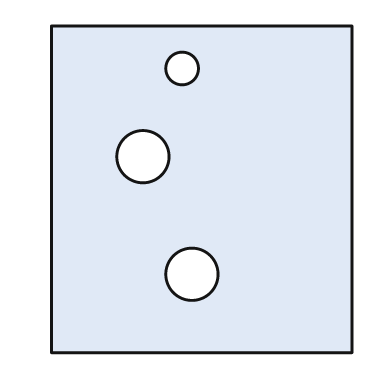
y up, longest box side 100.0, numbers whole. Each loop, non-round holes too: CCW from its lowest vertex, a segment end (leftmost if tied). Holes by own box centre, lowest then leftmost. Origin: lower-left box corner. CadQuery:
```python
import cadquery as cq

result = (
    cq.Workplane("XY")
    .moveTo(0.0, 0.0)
    .lineTo(92.0, 0.0)
    .lineTo(92.0, 100.0)
    .lineTo(0.0, 100.0)
    .close()
    .moveTo(43.0, 24.0)
    .circle(8.0)
    .moveTo(28.0, 60.0)
    .circle(8.0)
    .moveTo(40.0, 87.0)
    .circle(5.0)
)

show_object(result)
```